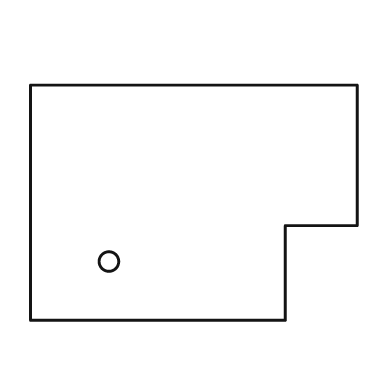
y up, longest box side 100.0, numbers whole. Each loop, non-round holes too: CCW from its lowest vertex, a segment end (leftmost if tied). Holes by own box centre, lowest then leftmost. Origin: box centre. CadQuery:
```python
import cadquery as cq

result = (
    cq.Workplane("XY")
    .moveTo(-50.0, -36.0)
    .lineTo(28.0, -36.0)
    .lineTo(28.0, -7.0)
    .lineTo(50.0, -7.0)
    .lineTo(50.0, 36.0)
    .lineTo(-50.0, 36.0)
    .close()
    .moveTo(-26.0, -18.0)
    .circle(3.0)
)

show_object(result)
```